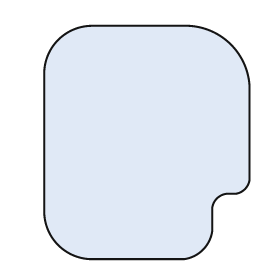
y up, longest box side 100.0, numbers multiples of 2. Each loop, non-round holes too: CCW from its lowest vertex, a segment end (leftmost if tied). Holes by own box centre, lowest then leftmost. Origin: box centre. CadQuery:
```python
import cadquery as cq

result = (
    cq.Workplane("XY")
    .moveTo(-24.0, -50.0)
    .lineTo(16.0, -50.0)
    .threePointArc((24.0, -46.0), (28.0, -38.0))
    .lineTo(28.0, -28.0)
    .threePointArc((30.0, -24.0), (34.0, -22.0))
    .lineTo(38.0, -22.0)
    .threePointArc((42.0, -20.0), (44.0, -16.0))
    .lineTo(44.0, 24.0)
    .threePointArc((36.0, 42.0), (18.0, 50.0))
    .lineTo(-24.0, 50.0)
    .threePointArc((-38.0, 44.0), (-44.0, 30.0))
    .lineTo(-44.0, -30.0)
    .threePointArc((-38.0, -44.0), (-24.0, -50.0))
    .close()
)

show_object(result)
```